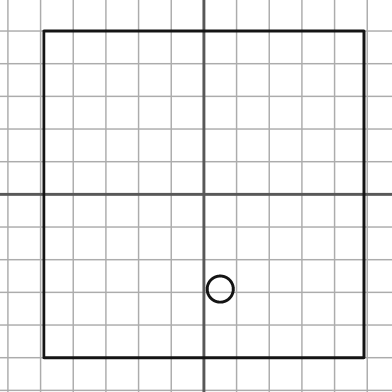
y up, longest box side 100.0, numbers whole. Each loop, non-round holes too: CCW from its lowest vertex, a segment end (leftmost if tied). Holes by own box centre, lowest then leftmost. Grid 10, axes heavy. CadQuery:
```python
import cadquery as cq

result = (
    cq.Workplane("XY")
    .moveTo(-49.0, -50.0)
    .lineTo(49.0, -50.0)
    .lineTo(49.0, 50.0)
    .lineTo(-49.0, 50.0)
    .close()
    .moveTo(5.0, -29.0)
    .circle(4.0)
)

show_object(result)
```